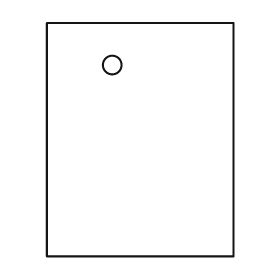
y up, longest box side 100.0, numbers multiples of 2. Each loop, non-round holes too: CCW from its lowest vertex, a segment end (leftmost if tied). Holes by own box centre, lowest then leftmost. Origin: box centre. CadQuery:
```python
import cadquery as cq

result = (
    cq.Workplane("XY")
    .moveTo(-40.0, -50.0)
    .lineTo(40.0, -50.0)
    .lineTo(40.0, 50.0)
    .lineTo(-40.0, 50.0)
    .close()
    .moveTo(-12.0, 32.0)
    .circle(4.0)
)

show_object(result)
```